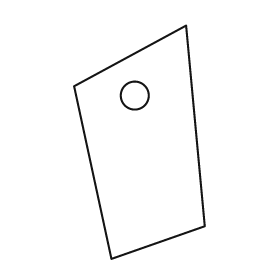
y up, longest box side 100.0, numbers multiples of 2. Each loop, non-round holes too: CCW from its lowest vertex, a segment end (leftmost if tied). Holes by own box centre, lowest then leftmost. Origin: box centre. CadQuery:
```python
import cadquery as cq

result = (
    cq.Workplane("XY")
    .moveTo(-12.0, -50.0)
    .lineTo(28.0, -36.0)
    .lineTo(20.0, 50.0)
    .lineTo(-28.0, 24.0)
    .close()
    .moveTo(-2.0, 20.0)
    .circle(6.0)
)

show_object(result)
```